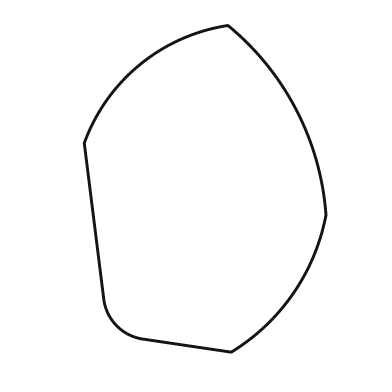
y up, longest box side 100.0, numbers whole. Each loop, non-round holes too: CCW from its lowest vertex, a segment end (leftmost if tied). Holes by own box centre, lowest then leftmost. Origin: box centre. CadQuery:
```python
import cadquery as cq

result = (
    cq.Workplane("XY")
    .moveTo(8.0, -50.0)
    .threePointArc((27.0, -32.0), (37.0, -8.0))
    .threePointArc((28.0, 24.0), (7.0, 50.0))
    .threePointArc((-20.0, 38.0), (-37.0, 14.0))
    .lineTo(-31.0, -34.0)
    .threePointArc((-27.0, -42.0), (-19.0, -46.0))
    .close()
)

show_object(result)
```